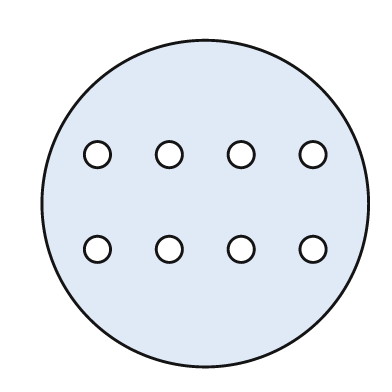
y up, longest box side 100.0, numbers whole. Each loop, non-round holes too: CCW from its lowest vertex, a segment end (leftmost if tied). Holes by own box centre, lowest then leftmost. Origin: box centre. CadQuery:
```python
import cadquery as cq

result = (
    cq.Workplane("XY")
    .moveTo(0.0, 0.0)
    .circle(50.0)
    .moveTo(-33.0, -14.0)
    .circle(4.0)
    .moveTo(-11.0, -14.0)
    .circle(4.0)
    .moveTo(11.0, -14.0)
    .circle(4.0)
    .moveTo(33.0, -14.0)
    .circle(4.0)
    .moveTo(-33.0, 15.0)
    .circle(4.0)
    .moveTo(-11.0, 15.0)
    .circle(4.0)
    .moveTo(11.0, 15.0)
    .circle(4.0)
    .moveTo(33.0, 15.0)
    .circle(4.0)
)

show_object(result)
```